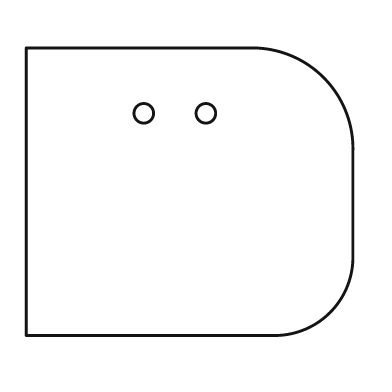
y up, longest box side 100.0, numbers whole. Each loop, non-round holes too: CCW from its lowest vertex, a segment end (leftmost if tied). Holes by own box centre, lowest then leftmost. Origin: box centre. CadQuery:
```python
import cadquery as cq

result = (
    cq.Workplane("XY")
    .moveTo(-50.0, -44.0)
    .lineTo(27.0, -44.0)
    .threePointArc((43.0, -37.0), (50.0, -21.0))
    .lineTo(50.0, 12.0)
    .threePointArc((41.0, 35.0), (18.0, 44.0))
    .lineTo(-50.0, 44.0)
    .close()
    .moveTo(-14.0, 24.0)
    .circle(3.0)
    .moveTo(5.0, 24.0)
    .circle(3.0)
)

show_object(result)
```